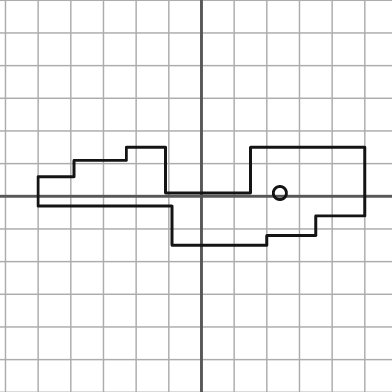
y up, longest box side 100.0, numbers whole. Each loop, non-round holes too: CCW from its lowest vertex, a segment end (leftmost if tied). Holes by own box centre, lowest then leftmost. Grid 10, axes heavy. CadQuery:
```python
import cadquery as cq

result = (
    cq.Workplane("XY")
    .moveTo(-9.0, -15.0)
    .lineTo(20.0, -15.0)
    .lineTo(20.0, -12.0)
    .lineTo(35.0, -12.0)
    .lineTo(35.0, -6.0)
    .lineTo(50.0, -6.0)
    .lineTo(50.0, 15.0)
    .lineTo(15.0, 15.0)
    .lineTo(15.0, 1.0)
    .lineTo(-11.0, 1.0)
    .lineTo(-11.0, 15.0)
    .lineTo(-23.0, 15.0)
    .lineTo(-23.0, 11.0)
    .lineTo(-39.0, 11.0)
    .lineTo(-39.0, 6.0)
    .lineTo(-50.0, 6.0)
    .lineTo(-50.0, -3.0)
    .lineTo(-9.0, -3.0)
    .close()
    .moveTo(24.0, 1.0)
    .circle(2.0)
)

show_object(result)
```